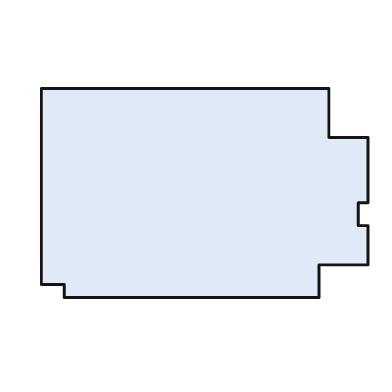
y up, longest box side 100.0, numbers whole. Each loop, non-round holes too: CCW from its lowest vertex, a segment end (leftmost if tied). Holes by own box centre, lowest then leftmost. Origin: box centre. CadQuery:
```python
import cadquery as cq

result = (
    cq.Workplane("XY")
    .moveTo(-43.0, -32.0)
    .lineTo(35.0, -32.0)
    .lineTo(35.0, -22.0)
    .lineTo(50.0, -22.0)
    .lineTo(50.0, -10.0)
    .lineTo(47.0, -10.0)
    .lineTo(47.0, -3.0)
    .lineTo(50.0, -3.0)
    .lineTo(50.0, 17.0)
    .lineTo(38.0, 17.0)
    .lineTo(38.0, 32.0)
    .lineTo(-50.0, 32.0)
    .lineTo(-50.0, -28.0)
    .lineTo(-43.0, -28.0)
    .close()
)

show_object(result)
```